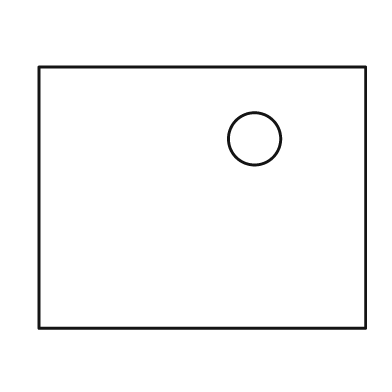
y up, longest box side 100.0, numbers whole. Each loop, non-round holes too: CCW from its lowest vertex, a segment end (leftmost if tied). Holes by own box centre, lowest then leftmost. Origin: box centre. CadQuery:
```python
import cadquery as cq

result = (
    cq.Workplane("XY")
    .moveTo(-50.0, -40.0)
    .lineTo(50.0, -40.0)
    .lineTo(50.0, 40.0)
    .lineTo(-50.0, 40.0)
    .close()
    .moveTo(16.0, 18.0)
    .circle(8.0)
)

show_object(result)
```